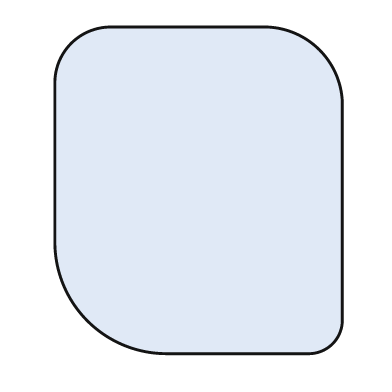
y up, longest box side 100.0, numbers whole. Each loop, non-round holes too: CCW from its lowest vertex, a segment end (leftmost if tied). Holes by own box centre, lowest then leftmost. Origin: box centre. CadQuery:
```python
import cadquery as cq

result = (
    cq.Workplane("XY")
    .moveTo(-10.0, -50.0)
    .lineTo(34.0, -50.0)
    .threePointArc((41.0, -47.0), (44.0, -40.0))
    .lineTo(44.0, 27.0)
    .threePointArc((37.0, 43.0), (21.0, 50.0))
    .lineTo(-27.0, 50.0)
    .threePointArc((-39.0, 45.0), (-44.0, 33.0))
    .lineTo(-44.0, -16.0)
    .threePointArc((-34.0, -40.0), (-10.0, -50.0))
    .close()
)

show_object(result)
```